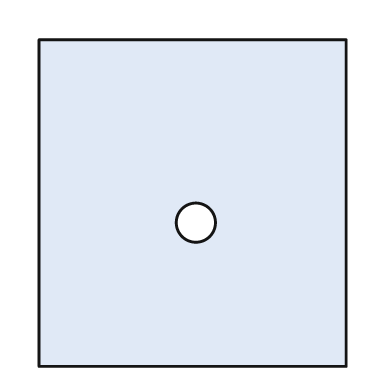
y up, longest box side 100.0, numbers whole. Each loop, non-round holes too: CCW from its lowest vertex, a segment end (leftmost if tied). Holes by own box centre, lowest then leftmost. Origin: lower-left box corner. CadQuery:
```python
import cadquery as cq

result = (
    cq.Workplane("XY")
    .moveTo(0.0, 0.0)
    .lineTo(94.0, 0.0)
    .lineTo(94.0, 100.0)
    .lineTo(0.0, 100.0)
    .close()
    .moveTo(48.0, 44.0)
    .circle(6.0)
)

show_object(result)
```